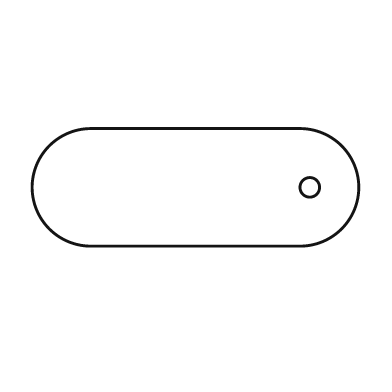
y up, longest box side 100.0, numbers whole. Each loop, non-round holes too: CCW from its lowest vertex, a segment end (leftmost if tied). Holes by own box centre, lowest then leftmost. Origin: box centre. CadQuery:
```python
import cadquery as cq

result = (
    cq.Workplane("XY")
    .moveTo(-32.0, -18.0)
    .lineTo(32.0, -18.0)
    .threePointArc((50.0, 0.0), (32.0, 18.0))
    .lineTo(-32.0, 18.0)
    .threePointArc((-50.0, 0.0), (-32.0, -18.0))
    .close()
    .moveTo(35.0, 0.0)
    .circle(3.0)
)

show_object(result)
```